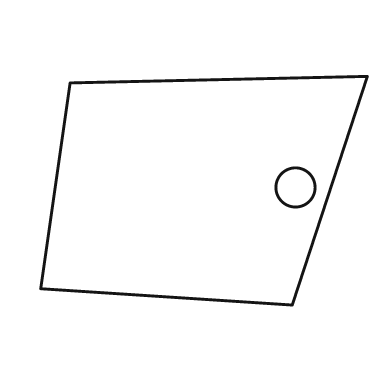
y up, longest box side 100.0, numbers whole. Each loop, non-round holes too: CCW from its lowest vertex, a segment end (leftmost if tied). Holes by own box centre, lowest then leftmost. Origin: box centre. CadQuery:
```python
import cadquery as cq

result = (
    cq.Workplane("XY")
    .moveTo(27.0, -35.0)
    .lineTo(50.0, 35.0)
    .lineTo(-41.0, 33.0)
    .lineTo(-50.0, -30.0)
    .close()
    .moveTo(28.0, 1.0)
    .circle(6.0)
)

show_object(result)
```